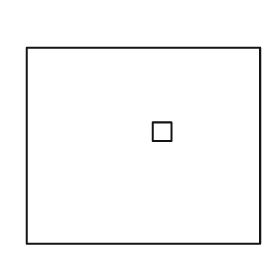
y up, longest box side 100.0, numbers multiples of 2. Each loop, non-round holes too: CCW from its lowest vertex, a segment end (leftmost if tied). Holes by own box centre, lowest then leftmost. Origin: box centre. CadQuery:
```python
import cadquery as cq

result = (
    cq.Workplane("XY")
    .moveTo(-50.0, -42.0)
    .lineTo(50.0, -42.0)
    .lineTo(50.0, 42.0)
    .lineTo(-50.0, 42.0)
    .close()
    .moveTo(4.0, 2.0)
    .lineTo(12.0, 2.0)
    .lineTo(12.0, 10.0)
    .lineTo(4.0, 10.0)
    .close()
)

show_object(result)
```